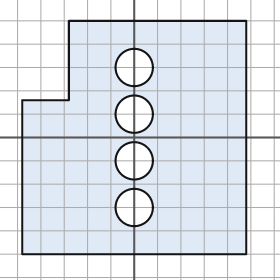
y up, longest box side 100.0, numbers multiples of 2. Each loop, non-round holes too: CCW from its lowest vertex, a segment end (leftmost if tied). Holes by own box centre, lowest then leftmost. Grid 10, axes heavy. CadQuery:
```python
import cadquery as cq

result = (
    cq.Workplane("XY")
    .moveTo(-48.0, -50.0)
    .lineTo(48.0, -50.0)
    .lineTo(48.0, 50.0)
    .lineTo(-28.0, 50.0)
    .lineTo(-28.0, 16.0)
    .lineTo(-48.0, 16.0)
    .close()
    .moveTo(0.0, -30.0)
    .circle(8.0)
    .moveTo(0.0, -10.0)
    .circle(8.0)
    .moveTo(0.0, 10.0)
    .circle(8.0)
    .moveTo(0.0, 30.0)
    .circle(8.0)
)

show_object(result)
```